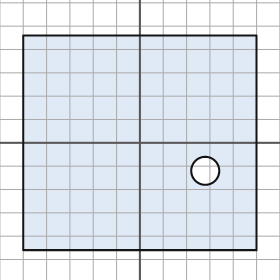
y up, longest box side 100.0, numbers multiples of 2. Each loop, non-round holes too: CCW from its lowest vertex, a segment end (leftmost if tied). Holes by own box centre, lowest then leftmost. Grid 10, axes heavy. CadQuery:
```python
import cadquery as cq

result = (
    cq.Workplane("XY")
    .moveTo(-50.0, -46.0)
    .lineTo(50.0, -46.0)
    .lineTo(50.0, 46.0)
    .lineTo(-50.0, 46.0)
    .close()
    .moveTo(28.0, -12.0)
    .circle(6.0)
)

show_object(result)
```